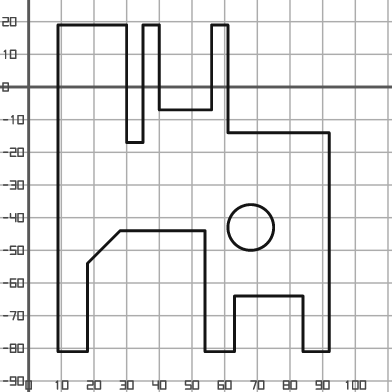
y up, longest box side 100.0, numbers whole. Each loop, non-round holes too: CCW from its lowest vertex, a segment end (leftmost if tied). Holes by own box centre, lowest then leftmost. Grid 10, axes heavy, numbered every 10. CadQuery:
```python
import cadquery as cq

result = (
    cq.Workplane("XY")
    .moveTo(9.0, -81.0)
    .lineTo(18.0, -81.0)
    .lineTo(18.0, -54.0)
    .lineTo(28.0, -44.0)
    .lineTo(54.0, -44.0)
    .lineTo(54.0, -81.0)
    .lineTo(63.0, -81.0)
    .lineTo(63.0, -64.0)
    .lineTo(84.0, -64.0)
    .lineTo(84.0, -81.0)
    .lineTo(92.0, -81.0)
    .lineTo(92.0, -14.0)
    .lineTo(61.0, -14.0)
    .lineTo(61.0, 19.0)
    .lineTo(56.0, 19.0)
    .lineTo(56.0, -7.0)
    .lineTo(40.0, -7.0)
    .lineTo(40.0, 19.0)
    .lineTo(35.0, 19.0)
    .lineTo(35.0, -17.0)
    .lineTo(30.0, -17.0)
    .lineTo(30.0, 19.0)
    .lineTo(9.0, 19.0)
    .close()
    .moveTo(68.0, -43.0)
    .circle(7.0)
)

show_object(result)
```